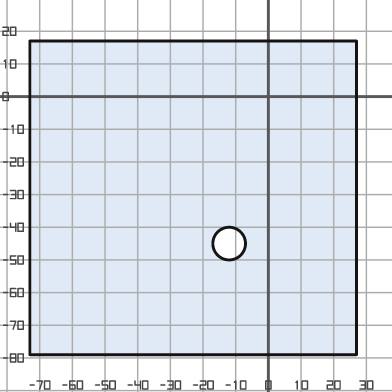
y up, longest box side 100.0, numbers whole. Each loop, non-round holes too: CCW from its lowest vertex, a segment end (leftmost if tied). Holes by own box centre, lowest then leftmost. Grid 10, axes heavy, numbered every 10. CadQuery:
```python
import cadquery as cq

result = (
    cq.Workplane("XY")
    .moveTo(-73.0, -79.0)
    .lineTo(27.0, -79.0)
    .lineTo(27.0, 17.0)
    .lineTo(-73.0, 17.0)
    .close()
    .moveTo(-12.0, -45.0)
    .circle(5.0)
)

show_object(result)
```